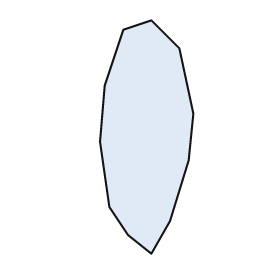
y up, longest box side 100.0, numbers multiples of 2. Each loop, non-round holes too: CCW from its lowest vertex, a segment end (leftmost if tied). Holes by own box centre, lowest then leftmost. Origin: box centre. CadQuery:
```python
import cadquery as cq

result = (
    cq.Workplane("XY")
    .moveTo(2.0, -50.0)
    .lineTo(10.0, -36.0)
    .lineTo(18.0, -10.0)
    .lineTo(20.0, 10.0)
    .lineTo(14.0, 38.0)
    .lineTo(2.0, 50.0)
    .lineTo(-10.0, 46.0)
    .lineTo(-18.0, 22.0)
    .lineTo(-20.0, -2.0)
    .lineTo(-16.0, -30.0)
    .lineTo(-8.0, -42.0)
    .close()
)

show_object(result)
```